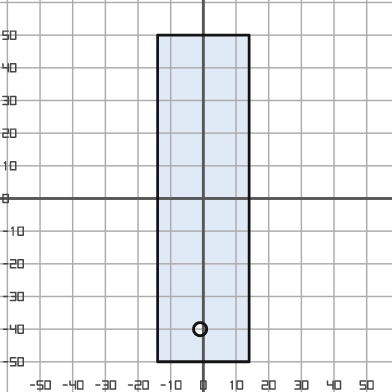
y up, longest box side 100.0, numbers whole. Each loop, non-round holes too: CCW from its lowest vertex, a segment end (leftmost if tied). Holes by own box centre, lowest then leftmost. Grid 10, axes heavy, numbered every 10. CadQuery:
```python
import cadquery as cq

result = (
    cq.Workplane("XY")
    .moveTo(-14.0, -50.0)
    .lineTo(14.0, -50.0)
    .lineTo(14.0, 50.0)
    .lineTo(-14.0, 50.0)
    .close()
    .moveTo(-1.0, -40.0)
    .circle(2.0)
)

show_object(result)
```